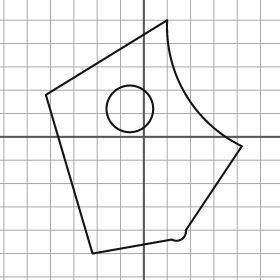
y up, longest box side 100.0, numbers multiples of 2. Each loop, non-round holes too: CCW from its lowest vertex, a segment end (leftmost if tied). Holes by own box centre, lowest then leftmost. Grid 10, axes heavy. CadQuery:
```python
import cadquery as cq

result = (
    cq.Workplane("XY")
    .moveTo(-22.0, -50.0)
    .lineTo(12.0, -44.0)
    .threePointArc((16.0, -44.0), (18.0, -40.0))
    .lineTo(42.0, -4.0)
    .threePointArc((18.0, 18.0), (10.0, 50.0))
    .lineTo(-42.0, 18.0)
    .close()
    .moveTo(-6.0, 12.0)
    .circle(10.0)
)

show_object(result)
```